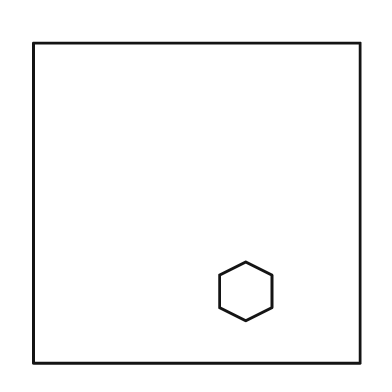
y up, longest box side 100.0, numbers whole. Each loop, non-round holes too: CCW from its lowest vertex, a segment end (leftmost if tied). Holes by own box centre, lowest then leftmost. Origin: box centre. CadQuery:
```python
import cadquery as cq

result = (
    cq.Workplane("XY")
    .moveTo(-50.0, -49.0)
    .lineTo(50.0, -49.0)
    .lineTo(50.0, 49.0)
    .lineTo(-50.0, 49.0)
    .close()
    .moveTo(15.0, -36.0)
    .lineTo(23.0, -32.0)
    .lineTo(23.0, -22.0)
    .lineTo(15.0, -18.0)
    .lineTo(7.0, -22.0)
    .lineTo(7.0, -32.0)
    .close()
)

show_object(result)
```